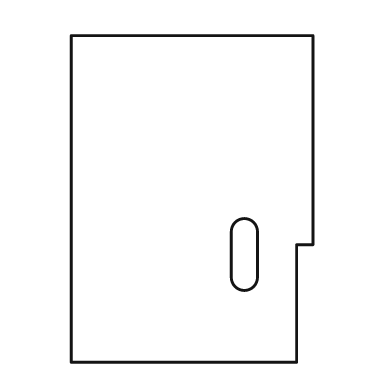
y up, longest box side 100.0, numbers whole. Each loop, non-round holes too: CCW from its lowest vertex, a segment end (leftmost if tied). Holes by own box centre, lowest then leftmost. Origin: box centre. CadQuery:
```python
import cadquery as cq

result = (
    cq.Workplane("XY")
    .moveTo(-37.0, -50.0)
    .lineTo(32.0, -50.0)
    .lineTo(32.0, -14.0)
    .lineTo(37.0, -14.0)
    .lineTo(37.0, 50.0)
    .lineTo(-37.0, 50.0)
    .close()
    .moveTo(12.0, -24.0)
    .threePointArc((16.0, -28.0), (20.0, -24.0))
    .lineTo(20.0, -10.0)
    .threePointArc((16.0, -6.0), (12.0, -10.0))
    .close()
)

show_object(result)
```